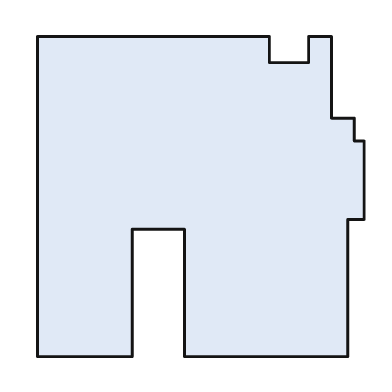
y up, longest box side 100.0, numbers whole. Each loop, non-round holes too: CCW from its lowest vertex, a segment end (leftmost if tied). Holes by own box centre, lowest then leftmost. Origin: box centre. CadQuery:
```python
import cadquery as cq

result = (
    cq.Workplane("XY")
    .moveTo(-50.0, -49.0)
    .lineTo(-21.0, -49.0)
    .lineTo(-21.0, -10.0)
    .lineTo(-5.0, -10.0)
    .lineTo(-5.0, -49.0)
    .lineTo(45.0, -49.0)
    .lineTo(45.0, -7.0)
    .lineTo(50.0, -7.0)
    .lineTo(50.0, 17.0)
    .lineTo(47.0, 17.0)
    .lineTo(47.0, 24.0)
    .lineTo(40.0, 24.0)
    .lineTo(40.0, 49.0)
    .lineTo(33.0, 49.0)
    .lineTo(33.0, 41.0)
    .lineTo(21.0, 41.0)
    .lineTo(21.0, 49.0)
    .lineTo(-50.0, 49.0)
    .close()
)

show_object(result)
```